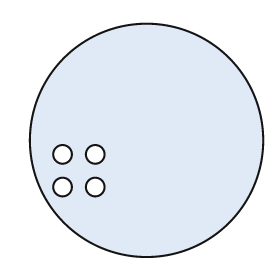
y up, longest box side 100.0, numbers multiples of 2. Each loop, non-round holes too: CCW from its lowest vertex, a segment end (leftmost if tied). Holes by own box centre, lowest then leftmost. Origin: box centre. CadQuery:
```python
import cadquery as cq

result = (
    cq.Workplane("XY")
    .moveTo(0.0, 0.0)
    .circle(50.0)
    .moveTo(-36.0, -20.0)
    .circle(4.0)
    .moveTo(-22.0, -20.0)
    .circle(4.0)
    .moveTo(-36.0, -6.0)
    .circle(4.0)
    .moveTo(-22.0, -6.0)
    .circle(4.0)
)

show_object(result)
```